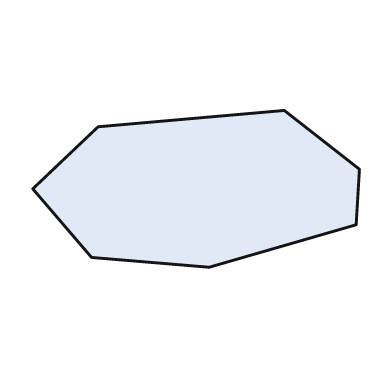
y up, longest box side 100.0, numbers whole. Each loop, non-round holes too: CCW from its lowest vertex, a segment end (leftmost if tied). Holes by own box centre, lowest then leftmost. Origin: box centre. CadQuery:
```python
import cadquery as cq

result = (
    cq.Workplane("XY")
    .moveTo(4.0, -24.0)
    .lineTo(49.0, -11.0)
    .lineTo(50.0, 6.0)
    .lineTo(27.0, 24.0)
    .lineTo(-30.0, 19.0)
    .lineTo(-50.0, 0.0)
    .lineTo(-32.0, -21.0)
    .close()
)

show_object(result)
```